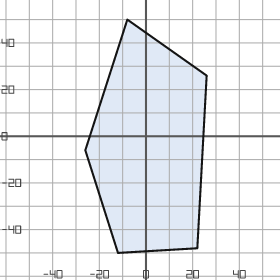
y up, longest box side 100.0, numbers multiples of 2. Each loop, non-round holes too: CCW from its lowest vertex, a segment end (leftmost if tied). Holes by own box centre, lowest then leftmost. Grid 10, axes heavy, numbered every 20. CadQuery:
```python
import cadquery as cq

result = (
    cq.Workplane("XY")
    .moveTo(-12.0, -50.0)
    .lineTo(22.0, -48.0)
    .lineTo(26.0, 26.0)
    .lineTo(-8.0, 50.0)
    .lineTo(-26.0, -6.0)
    .close()
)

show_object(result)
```